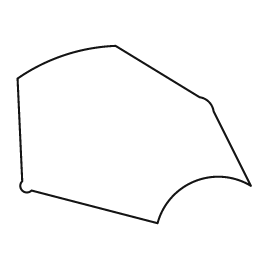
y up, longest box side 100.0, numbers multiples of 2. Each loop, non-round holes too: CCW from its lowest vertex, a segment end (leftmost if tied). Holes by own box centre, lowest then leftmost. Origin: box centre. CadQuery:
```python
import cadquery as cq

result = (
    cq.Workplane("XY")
    .moveTo(10.0, -38.0)
    .threePointArc((26.0, -20.0), (50.0, -22.0))
    .lineTo(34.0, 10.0)
    .threePointArc((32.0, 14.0), (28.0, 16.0))
    .lineTo(-8.0, 38.0)
    .threePointArc((-30.0, 34.0), (-50.0, 24.0))
    .lineTo(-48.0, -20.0)
    .threePointArc((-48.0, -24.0), (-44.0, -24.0))
    .close()
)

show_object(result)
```